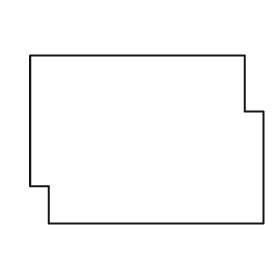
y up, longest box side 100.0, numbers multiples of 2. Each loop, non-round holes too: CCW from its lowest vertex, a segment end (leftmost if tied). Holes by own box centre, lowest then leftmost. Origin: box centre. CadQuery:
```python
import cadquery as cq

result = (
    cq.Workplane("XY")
    .moveTo(-42.0, -36.0)
    .lineTo(50.0, -36.0)
    .lineTo(50.0, 12.0)
    .lineTo(42.0, 12.0)
    .lineTo(42.0, 36.0)
    .lineTo(-50.0, 36.0)
    .lineTo(-50.0, -20.0)
    .lineTo(-42.0, -20.0)
    .close()
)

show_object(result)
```